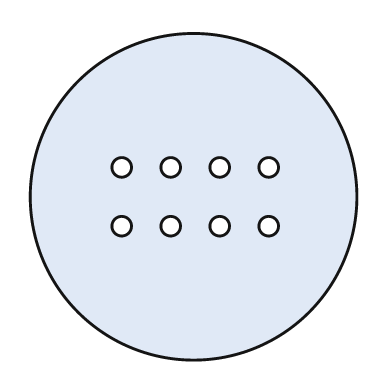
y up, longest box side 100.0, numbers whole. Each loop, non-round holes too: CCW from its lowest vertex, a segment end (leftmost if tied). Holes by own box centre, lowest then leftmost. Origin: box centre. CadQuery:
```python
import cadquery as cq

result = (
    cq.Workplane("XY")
    .moveTo(0.0, 0.0)
    .circle(50.0)
    .moveTo(-22.0, -9.0)
    .circle(3.0)
    .moveTo(-7.0, -9.0)
    .circle(3.0)
    .moveTo(8.0, -9.0)
    .circle(3.0)
    .moveTo(23.0, -9.0)
    .circle(3.0)
    .moveTo(-22.0, 9.0)
    .circle(3.0)
    .moveTo(-7.0, 9.0)
    .circle(3.0)
    .moveTo(8.0, 9.0)
    .circle(3.0)
    .moveTo(23.0, 9.0)
    .circle(3.0)
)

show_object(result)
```